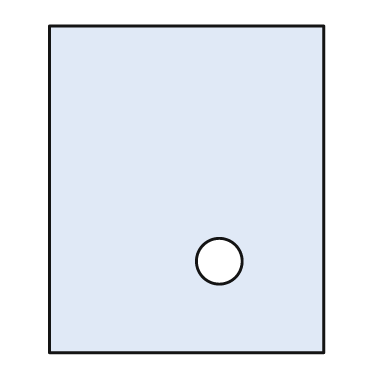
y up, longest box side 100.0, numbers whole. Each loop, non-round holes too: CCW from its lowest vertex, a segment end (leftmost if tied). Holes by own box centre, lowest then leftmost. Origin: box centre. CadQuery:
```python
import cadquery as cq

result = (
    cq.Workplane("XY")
    .moveTo(-42.0, -50.0)
    .lineTo(42.0, -50.0)
    .lineTo(42.0, 50.0)
    .lineTo(-42.0, 50.0)
    .close()
    .moveTo(10.0, -22.0)
    .circle(7.0)
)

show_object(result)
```